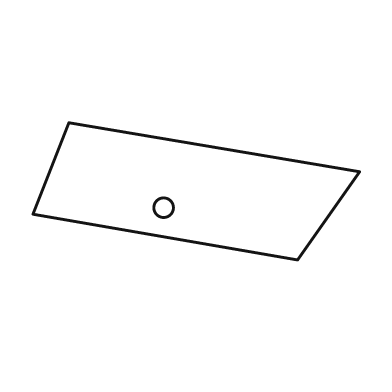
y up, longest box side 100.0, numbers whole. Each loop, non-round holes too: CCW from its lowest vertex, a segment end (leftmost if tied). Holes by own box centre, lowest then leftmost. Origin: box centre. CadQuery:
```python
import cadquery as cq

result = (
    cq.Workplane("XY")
    .moveTo(31.0, -21.0)
    .lineTo(50.0, 6.0)
    .lineTo(-39.0, 21.0)
    .lineTo(-50.0, -7.0)
    .close()
    .moveTo(-10.0, -5.0)
    .circle(3.0)
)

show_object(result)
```